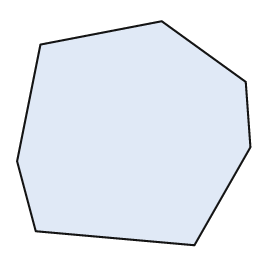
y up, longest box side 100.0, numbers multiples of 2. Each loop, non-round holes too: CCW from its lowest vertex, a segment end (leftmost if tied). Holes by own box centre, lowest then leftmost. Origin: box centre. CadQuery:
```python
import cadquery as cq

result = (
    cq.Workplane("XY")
    .moveTo(26.0, -48.0)
    .lineTo(50.0, -6.0)
    .lineTo(48.0, 22.0)
    .lineTo(12.0, 48.0)
    .lineTo(-40.0, 38.0)
    .lineTo(-50.0, -12.0)
    .lineTo(-42.0, -42.0)
    .close()
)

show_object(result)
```